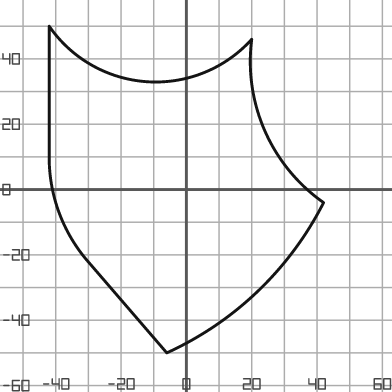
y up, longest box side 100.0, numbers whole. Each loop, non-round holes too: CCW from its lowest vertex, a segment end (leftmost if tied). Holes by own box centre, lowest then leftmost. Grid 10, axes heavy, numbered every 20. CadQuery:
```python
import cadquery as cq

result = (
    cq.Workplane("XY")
    .moveTo(-6.0, -50.0)
    .threePointArc((22.0, -31.0), (42.0, -4.0))
    .threePointArc((24.0, 18.0), (20.0, 46.0))
    .threePointArc((-12.0, 33.0), (-42.0, 50.0))
    .lineTo(-42.0, 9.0)
    .threePointArc((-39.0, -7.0), (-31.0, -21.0))
    .close()
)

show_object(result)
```